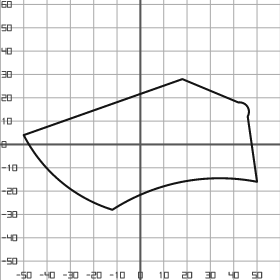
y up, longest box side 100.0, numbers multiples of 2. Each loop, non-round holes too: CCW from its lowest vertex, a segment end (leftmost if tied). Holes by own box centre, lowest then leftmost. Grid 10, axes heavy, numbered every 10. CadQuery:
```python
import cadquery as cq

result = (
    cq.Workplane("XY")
    .moveTo(-12.0, -28.0)
    .threePointArc((18.0, -16.0), (50.0, -16.0))
    .lineTo(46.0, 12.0)
    .threePointArc((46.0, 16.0), (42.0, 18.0))
    .lineTo(18.0, 28.0)
    .lineTo(-50.0, 4.0)
    .threePointArc((-34.0, -16.0), (-12.0, -28.0))
    .close()
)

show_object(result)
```